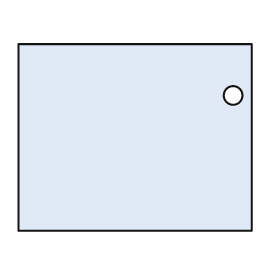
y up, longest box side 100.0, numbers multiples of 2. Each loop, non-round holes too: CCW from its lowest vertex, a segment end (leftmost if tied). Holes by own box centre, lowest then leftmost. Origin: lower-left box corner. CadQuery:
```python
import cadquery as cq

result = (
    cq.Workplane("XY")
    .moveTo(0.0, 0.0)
    .lineTo(100.0, 0.0)
    .lineTo(100.0, 80.0)
    .lineTo(0.0, 80.0)
    .close()
    .moveTo(92.0, 58.0)
    .circle(4.0)
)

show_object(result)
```